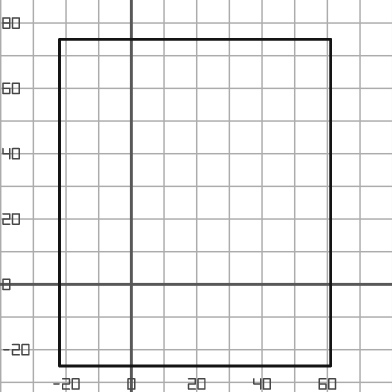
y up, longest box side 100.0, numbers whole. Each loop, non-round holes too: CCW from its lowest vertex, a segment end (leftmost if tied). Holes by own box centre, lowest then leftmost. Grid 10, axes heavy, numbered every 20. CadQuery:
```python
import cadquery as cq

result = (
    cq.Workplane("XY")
    .moveTo(-22.0, -25.0)
    .lineTo(61.0, -25.0)
    .lineTo(61.0, 75.0)
    .lineTo(-22.0, 75.0)
    .close()
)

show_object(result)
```